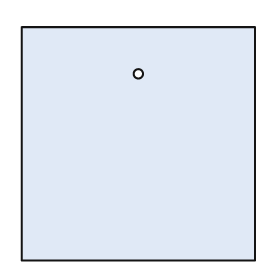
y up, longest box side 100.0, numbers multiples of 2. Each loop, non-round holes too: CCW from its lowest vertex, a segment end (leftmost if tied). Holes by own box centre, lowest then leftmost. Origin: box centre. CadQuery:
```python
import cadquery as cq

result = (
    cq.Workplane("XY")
    .moveTo(-50.0, -50.0)
    .lineTo(50.0, -50.0)
    .lineTo(50.0, 50.0)
    .lineTo(-50.0, 50.0)
    .close()
    .moveTo(0.0, 30.0)
    .circle(2.0)
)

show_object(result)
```